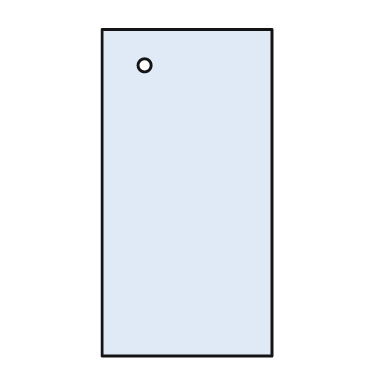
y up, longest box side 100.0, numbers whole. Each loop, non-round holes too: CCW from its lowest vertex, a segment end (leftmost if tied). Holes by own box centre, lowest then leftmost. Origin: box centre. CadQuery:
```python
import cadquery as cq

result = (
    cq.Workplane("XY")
    .moveTo(-26.0, -50.0)
    .lineTo(26.0, -50.0)
    .lineTo(26.0, 50.0)
    .lineTo(-26.0, 50.0)
    .close()
    .moveTo(-13.0, 39.0)
    .circle(2.0)
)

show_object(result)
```